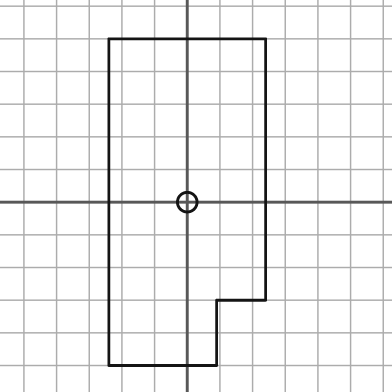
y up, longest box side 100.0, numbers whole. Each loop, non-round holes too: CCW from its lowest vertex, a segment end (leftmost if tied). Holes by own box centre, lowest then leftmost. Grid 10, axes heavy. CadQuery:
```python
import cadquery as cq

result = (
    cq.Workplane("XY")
    .moveTo(-24.0, -50.0)
    .lineTo(9.0, -50.0)
    .lineTo(9.0, -30.0)
    .lineTo(24.0, -30.0)
    .lineTo(24.0, 50.0)
    .lineTo(-24.0, 50.0)
    .close()
    .moveTo(0.0, 0.0)
    .circle(3.0)
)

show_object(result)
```